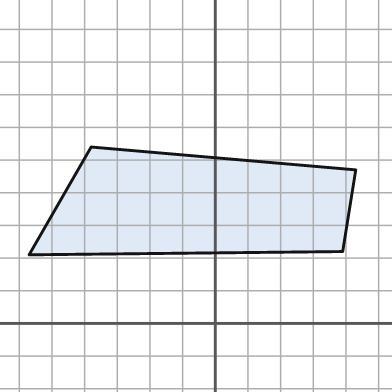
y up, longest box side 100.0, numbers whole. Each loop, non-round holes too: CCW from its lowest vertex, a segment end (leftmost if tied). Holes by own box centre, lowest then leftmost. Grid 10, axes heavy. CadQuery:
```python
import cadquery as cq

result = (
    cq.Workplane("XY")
    .moveTo(-57.0, 21.0)
    .lineTo(39.0, 22.0)
    .lineTo(43.0, 47.0)
    .lineTo(-38.0, 54.0)
    .close()
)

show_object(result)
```